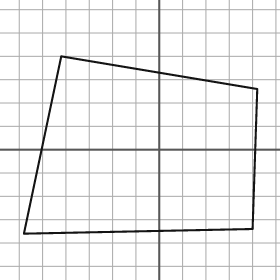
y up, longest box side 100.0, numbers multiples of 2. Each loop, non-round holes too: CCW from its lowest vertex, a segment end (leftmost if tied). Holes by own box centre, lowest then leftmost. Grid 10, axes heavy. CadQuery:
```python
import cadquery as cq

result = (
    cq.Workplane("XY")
    .moveTo(-58.0, -36.0)
    .lineTo(40.0, -34.0)
    .lineTo(42.0, 26.0)
    .lineTo(-42.0, 40.0)
    .close()
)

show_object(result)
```